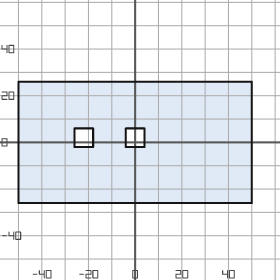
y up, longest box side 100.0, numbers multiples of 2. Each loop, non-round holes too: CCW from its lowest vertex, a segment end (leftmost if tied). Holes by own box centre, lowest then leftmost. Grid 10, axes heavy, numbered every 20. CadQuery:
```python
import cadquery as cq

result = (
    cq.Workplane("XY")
    .moveTo(-50.0, -26.0)
    .lineTo(50.0, -26.0)
    .lineTo(50.0, 26.0)
    .lineTo(-50.0, 26.0)
    .close()
    .moveTo(-26.0, -2.0)
    .lineTo(-18.0, -2.0)
    .lineTo(-18.0, 6.0)
    .lineTo(-26.0, 6.0)
    .close()
    .moveTo(-4.0, -2.0)
    .lineTo(4.0, -2.0)
    .lineTo(4.0, 6.0)
    .lineTo(-4.0, 6.0)
    .close()
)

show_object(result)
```